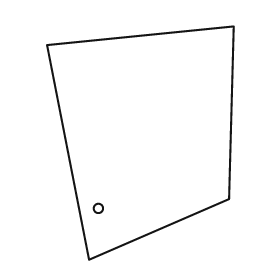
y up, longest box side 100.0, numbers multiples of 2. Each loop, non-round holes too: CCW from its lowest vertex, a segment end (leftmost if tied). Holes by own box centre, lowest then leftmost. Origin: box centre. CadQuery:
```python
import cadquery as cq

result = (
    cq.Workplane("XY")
    .moveTo(-22.0, -50.0)
    .lineTo(38.0, -24.0)
    .lineTo(40.0, 50.0)
    .lineTo(-40.0, 42.0)
    .close()
    .moveTo(-18.0, -28.0)
    .circle(2.0)
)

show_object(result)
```